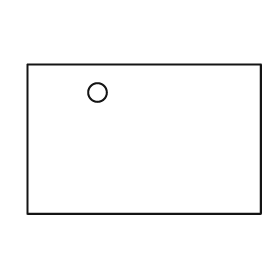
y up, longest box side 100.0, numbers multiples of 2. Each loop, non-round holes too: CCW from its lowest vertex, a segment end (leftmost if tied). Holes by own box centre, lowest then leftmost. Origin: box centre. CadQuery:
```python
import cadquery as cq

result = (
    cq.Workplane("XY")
    .moveTo(-50.0, -32.0)
    .lineTo(50.0, -32.0)
    .lineTo(50.0, 32.0)
    .lineTo(-50.0, 32.0)
    .close()
    .moveTo(-20.0, 20.0)
    .circle(4.0)
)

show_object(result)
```